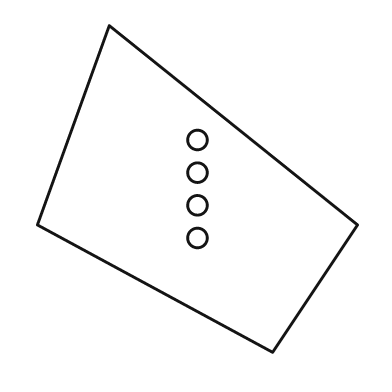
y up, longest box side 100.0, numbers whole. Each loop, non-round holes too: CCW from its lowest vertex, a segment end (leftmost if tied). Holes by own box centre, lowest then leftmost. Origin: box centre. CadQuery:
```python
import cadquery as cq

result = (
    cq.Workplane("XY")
    .moveTo(23.0, -50.0)
    .lineTo(49.0, -11.0)
    .lineTo(-27.0, 50.0)
    .lineTo(-49.0, -11.0)
    .close()
    .moveTo(0.0, -15.0)
    .circle(3.0)
    .moveTo(0.0, -5.0)
    .circle(3.0)
    .moveTo(0.0, 5.0)
    .circle(3.0)
    .moveTo(0.0, 15.0)
    .circle(3.0)
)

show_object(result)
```